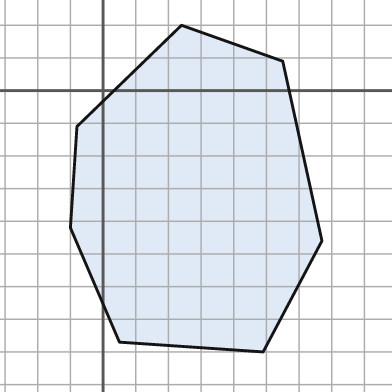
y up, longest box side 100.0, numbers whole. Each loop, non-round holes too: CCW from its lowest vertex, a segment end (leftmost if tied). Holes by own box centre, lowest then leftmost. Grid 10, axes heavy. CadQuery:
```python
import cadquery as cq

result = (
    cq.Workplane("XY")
    .moveTo(49.0, -80.0)
    .lineTo(67.0, -46.0)
    .lineTo(55.0, 9.0)
    .lineTo(24.0, 20.0)
    .lineTo(-8.0, -11.0)
    .lineTo(-10.0, -42.0)
    .lineTo(5.0, -77.0)
    .close()
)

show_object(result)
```